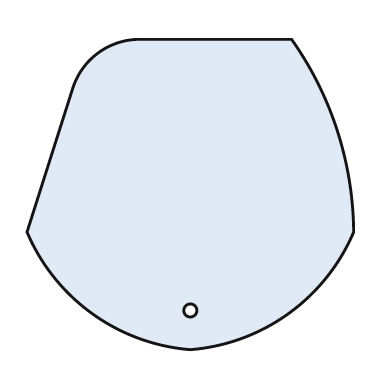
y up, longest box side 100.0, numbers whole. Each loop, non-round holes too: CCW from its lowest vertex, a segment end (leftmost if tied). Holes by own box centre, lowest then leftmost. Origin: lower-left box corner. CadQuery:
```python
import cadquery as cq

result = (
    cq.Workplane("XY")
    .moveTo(50.0, 0.0)
    .threePointArc((80.0, 11.0), (100.0, 36.0))
    .threePointArc((95.0, 67.0), (81.0, 95.0))
    .lineTo(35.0, 95.0)
    .threePointArc((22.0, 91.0), (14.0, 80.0))
    .lineTo(0.0, 36.0)
    .threePointArc((20.0, 11.0), (50.0, 0.0))
    .close()
    .moveTo(50.0, 12.0)
    .circle(2.0)
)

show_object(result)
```